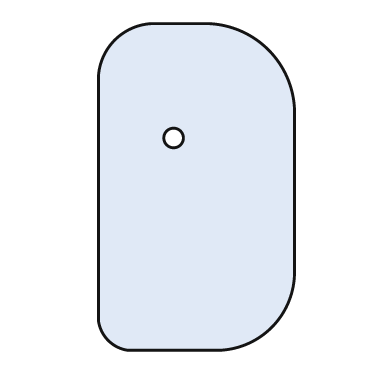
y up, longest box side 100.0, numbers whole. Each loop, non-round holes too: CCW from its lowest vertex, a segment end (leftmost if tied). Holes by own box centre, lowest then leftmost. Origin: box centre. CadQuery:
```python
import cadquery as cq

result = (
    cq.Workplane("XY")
    .moveTo(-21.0, -50.0)
    .lineTo(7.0, -50.0)
    .threePointArc((23.0, -43.0), (30.0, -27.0))
    .lineTo(30.0, 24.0)
    .threePointArc((22.0, 42.0), (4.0, 50.0))
    .lineTo(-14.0, 50.0)
    .threePointArc((-25.0, 45.0), (-30.0, 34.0))
    .lineTo(-30.0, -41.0)
    .threePointArc((-27.0, -47.0), (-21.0, -50.0))
    .close()
    .moveTo(-7.0, 15.0)
    .circle(3.0)
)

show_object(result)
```